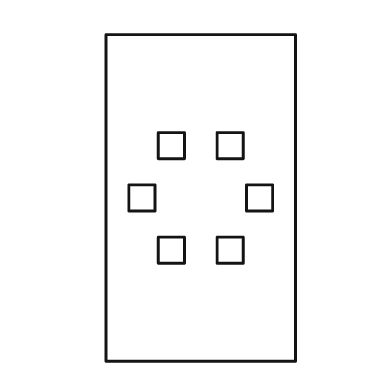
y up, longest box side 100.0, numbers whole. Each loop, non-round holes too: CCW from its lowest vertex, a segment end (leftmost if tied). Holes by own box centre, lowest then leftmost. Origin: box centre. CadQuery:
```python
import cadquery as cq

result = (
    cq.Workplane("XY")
    .moveTo(-29.0, -50.0)
    .lineTo(29.0, -50.0)
    .lineTo(29.0, 50.0)
    .lineTo(-29.0, 50.0)
    .close()
    .moveTo(-13.0, -20.0)
    .lineTo(-5.0, -20.0)
    .lineTo(-5.0, -12.0)
    .lineTo(-13.0, -12.0)
    .close()
    .moveTo(5.0, -20.0)
    .lineTo(13.0, -20.0)
    .lineTo(13.0, -12.0)
    .lineTo(5.0, -12.0)
    .close()
    .moveTo(-22.0, -4.0)
    .lineTo(-14.0, -4.0)
    .lineTo(-14.0, 4.0)
    .lineTo(-22.0, 4.0)
    .close()
    .moveTo(14.0, -4.0)
    .lineTo(22.0, -4.0)
    .lineTo(22.0, 4.0)
    .lineTo(14.0, 4.0)
    .close()
    .moveTo(-13.0, 12.0)
    .lineTo(-5.0, 12.0)
    .lineTo(-5.0, 20.0)
    .lineTo(-13.0, 20.0)
    .close()
    .moveTo(5.0, 12.0)
    .lineTo(13.0, 12.0)
    .lineTo(13.0, 20.0)
    .lineTo(5.0, 20.0)
    .close()
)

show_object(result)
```